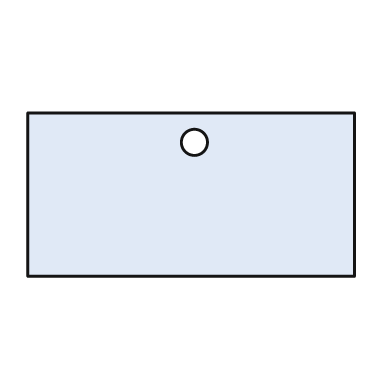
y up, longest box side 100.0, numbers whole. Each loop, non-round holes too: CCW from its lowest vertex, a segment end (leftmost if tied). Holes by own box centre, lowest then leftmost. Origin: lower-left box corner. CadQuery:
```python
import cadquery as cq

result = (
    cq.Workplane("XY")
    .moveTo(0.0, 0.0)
    .lineTo(100.0, 0.0)
    .lineTo(100.0, 50.0)
    .lineTo(0.0, 50.0)
    .close()
    .moveTo(51.0, 41.0)
    .circle(4.0)
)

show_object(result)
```